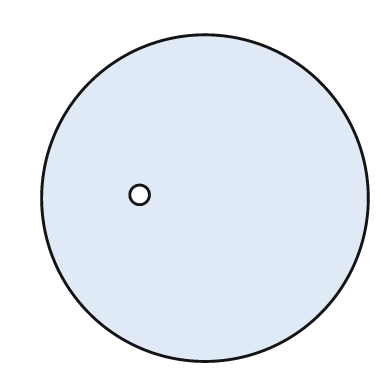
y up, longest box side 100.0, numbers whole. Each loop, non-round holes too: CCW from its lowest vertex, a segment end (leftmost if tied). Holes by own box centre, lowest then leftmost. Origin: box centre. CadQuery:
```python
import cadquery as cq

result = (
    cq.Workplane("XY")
    .moveTo(0.0, 0.0)
    .circle(50.0)
    .moveTo(-20.0, 1.0)
    .circle(3.0)
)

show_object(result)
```